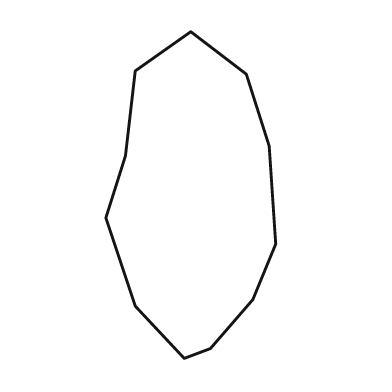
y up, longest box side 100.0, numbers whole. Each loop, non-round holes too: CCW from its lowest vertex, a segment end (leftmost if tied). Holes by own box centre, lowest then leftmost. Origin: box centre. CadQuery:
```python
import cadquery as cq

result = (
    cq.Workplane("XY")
    .moveTo(-2.0, -50.0)
    .lineTo(6.0, -47.0)
    .lineTo(19.0, -32.0)
    .lineTo(26.0, -15.0)
    .lineTo(24.0, 15.0)
    .lineTo(17.0, 37.0)
    .lineTo(0.0, 50.0)
    .lineTo(-17.0, 38.0)
    .lineTo(-20.0, 12.0)
    .lineTo(-26.0, -7.0)
    .lineTo(-17.0, -34.0)
    .close()
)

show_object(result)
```